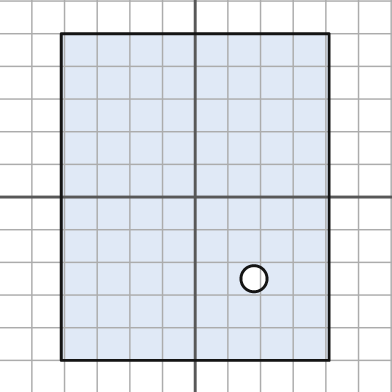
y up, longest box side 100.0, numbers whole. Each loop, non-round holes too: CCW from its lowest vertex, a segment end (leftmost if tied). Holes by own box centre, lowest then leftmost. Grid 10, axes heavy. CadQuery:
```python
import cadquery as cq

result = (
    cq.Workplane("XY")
    .moveTo(-41.0, -50.0)
    .lineTo(41.0, -50.0)
    .lineTo(41.0, 50.0)
    .lineTo(-41.0, 50.0)
    .close()
    .moveTo(18.0, -25.0)
    .circle(4.0)
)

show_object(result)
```